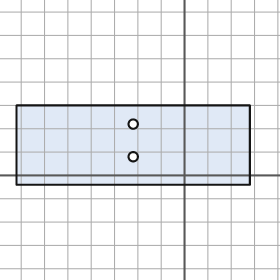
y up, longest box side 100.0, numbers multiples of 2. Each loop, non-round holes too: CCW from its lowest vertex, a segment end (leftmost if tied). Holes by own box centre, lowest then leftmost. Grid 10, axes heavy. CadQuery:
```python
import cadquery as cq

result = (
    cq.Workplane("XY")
    .moveTo(-72.0, -4.0)
    .lineTo(28.0, -4.0)
    .lineTo(28.0, 30.0)
    .lineTo(-72.0, 30.0)
    .close()
    .moveTo(-22.0, 8.0)
    .circle(2.0)
    .moveTo(-22.0, 22.0)
    .circle(2.0)
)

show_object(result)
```